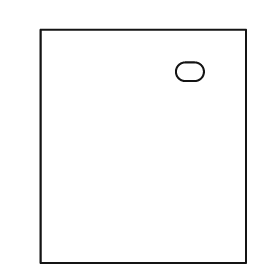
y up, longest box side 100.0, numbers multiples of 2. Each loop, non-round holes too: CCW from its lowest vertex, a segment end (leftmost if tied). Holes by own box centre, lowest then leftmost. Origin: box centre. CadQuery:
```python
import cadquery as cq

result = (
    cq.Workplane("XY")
    .moveTo(-44.0, -50.0)
    .lineTo(44.0, -50.0)
    .lineTo(44.0, 50.0)
    .lineTo(-44.0, 50.0)
    .close()
    .moveTo(18.0, 28.0)
    .lineTo(22.0, 28.0)
    .threePointArc((26.0, 32.0), (22.0, 36.0))
    .lineTo(18.0, 36.0)
    .threePointArc((14.0, 32.0), (18.0, 28.0))
    .close()
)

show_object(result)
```